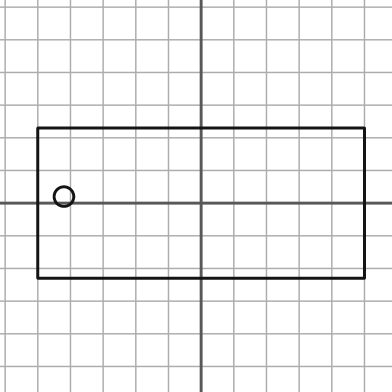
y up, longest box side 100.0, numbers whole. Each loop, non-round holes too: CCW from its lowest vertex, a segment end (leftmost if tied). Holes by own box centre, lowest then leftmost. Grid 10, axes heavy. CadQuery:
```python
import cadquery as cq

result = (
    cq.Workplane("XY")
    .moveTo(-50.0, -23.0)
    .lineTo(50.0, -23.0)
    .lineTo(50.0, 23.0)
    .lineTo(-50.0, 23.0)
    .close()
    .moveTo(-42.0, 2.0)
    .circle(3.0)
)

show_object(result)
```